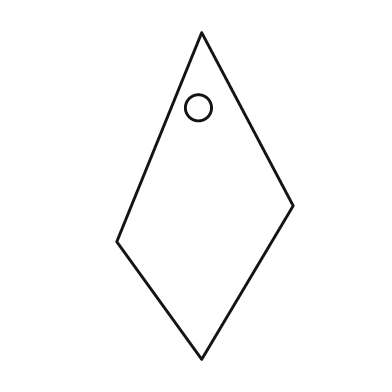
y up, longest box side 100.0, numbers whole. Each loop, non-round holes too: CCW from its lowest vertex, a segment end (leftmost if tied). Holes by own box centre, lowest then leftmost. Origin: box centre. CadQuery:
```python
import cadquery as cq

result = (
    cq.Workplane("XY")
    .moveTo(-1.0, -50.0)
    .lineTo(27.0, -3.0)
    .lineTo(-1.0, 50.0)
    .lineTo(-27.0, -14.0)
    .close()
    .moveTo(-2.0, 27.0)
    .circle(4.0)
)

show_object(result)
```